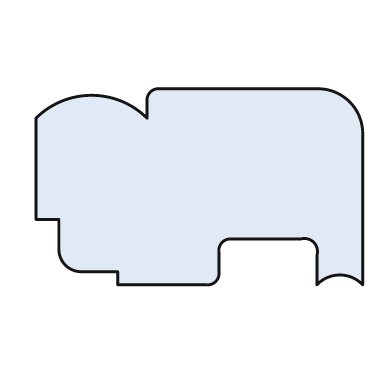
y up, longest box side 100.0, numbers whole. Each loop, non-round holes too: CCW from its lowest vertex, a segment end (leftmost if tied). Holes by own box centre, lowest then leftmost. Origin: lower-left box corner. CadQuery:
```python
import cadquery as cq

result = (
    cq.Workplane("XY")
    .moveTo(25.0, 0.0)
    .lineTo(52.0, 0.0)
    .threePointArc((55.0, 1.0), (56.0, 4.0))
    .lineTo(56.0, 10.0)
    .threePointArc((57.0, 13.0), (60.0, 14.0))
    .lineTo(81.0, 14.0)
    .threePointArc((85.0, 13.0), (86.0, 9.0))
    .lineTo(86.0, 0.0)
    .threePointArc((93.0, 3.0), (100.0, 0.0))
    .lineTo(100.0, 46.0)
    .threePointArc((96.0, 56.0), (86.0, 60.0))
    .lineTo(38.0, 60.0)
    .threePointArc((35.0, 59.0), (34.0, 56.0))
    .lineTo(34.0, 51.0)
    .threePointArc((17.0, 58.0), (0.0, 51.0))
    .lineTo(0.0, 20.0)
    .lineTo(7.0, 20.0)
    .lineTo(7.0, 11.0)
    .threePointArc((9.0, 6.0), (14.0, 4.0))
    .lineTo(25.0, 4.0)
    .close()
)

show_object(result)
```